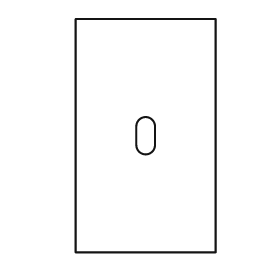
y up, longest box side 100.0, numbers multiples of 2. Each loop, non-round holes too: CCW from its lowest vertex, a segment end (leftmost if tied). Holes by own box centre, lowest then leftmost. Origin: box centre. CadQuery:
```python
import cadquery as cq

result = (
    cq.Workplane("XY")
    .moveTo(-30.0, -50.0)
    .lineTo(30.0, -50.0)
    .lineTo(30.0, 50.0)
    .lineTo(-30.0, 50.0)
    .close()
    .moveTo(-4.0, -4.0)
    .threePointArc((0.0, -8.0), (4.0, -4.0))
    .lineTo(4.0, 4.0)
    .threePointArc((0.0, 8.0), (-4.0, 4.0))
    .close()
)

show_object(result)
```